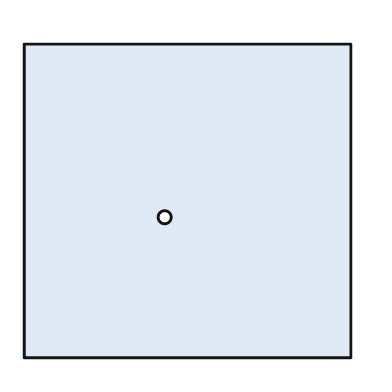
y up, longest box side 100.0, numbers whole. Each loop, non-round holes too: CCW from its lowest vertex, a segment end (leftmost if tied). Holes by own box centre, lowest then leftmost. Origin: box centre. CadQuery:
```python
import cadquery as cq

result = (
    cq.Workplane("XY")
    .moveTo(-50.0, -48.0)
    .lineTo(50.0, -48.0)
    .lineTo(50.0, 48.0)
    .lineTo(-50.0, 48.0)
    .close()
    .moveTo(-7.0, -5.0)
    .circle(2.0)
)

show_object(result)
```